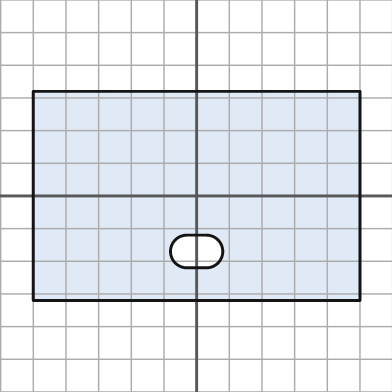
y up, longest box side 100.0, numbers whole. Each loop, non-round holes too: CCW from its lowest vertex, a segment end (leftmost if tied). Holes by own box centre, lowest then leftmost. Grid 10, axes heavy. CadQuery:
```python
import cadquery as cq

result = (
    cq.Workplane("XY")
    .moveTo(-50.0, -32.0)
    .lineTo(50.0, -32.0)
    .lineTo(50.0, 32.0)
    .lineTo(-50.0, 32.0)
    .close()
    .moveTo(-3.0, -22.0)
    .lineTo(3.0, -22.0)
    .threePointArc((8.0, -17.0), (3.0, -12.0))
    .lineTo(-3.0, -12.0)
    .threePointArc((-8.0, -17.0), (-3.0, -22.0))
    .close()
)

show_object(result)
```